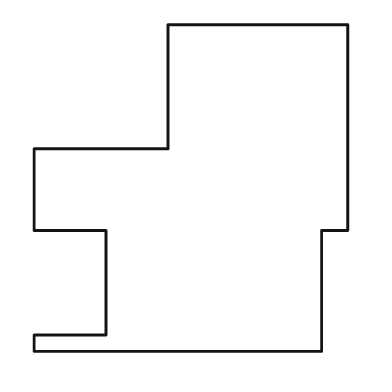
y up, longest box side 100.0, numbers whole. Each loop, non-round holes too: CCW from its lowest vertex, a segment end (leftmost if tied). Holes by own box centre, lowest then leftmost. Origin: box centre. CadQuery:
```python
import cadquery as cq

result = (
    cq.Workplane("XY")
    .moveTo(-48.0, -50.0)
    .lineTo(40.0, -50.0)
    .lineTo(40.0, -13.0)
    .lineTo(48.0, -13.0)
    .lineTo(48.0, 50.0)
    .lineTo(-7.0, 50.0)
    .lineTo(-7.0, 12.0)
    .lineTo(-48.0, 12.0)
    .lineTo(-48.0, -13.0)
    .lineTo(-26.0, -13.0)
    .lineTo(-26.0, -45.0)
    .lineTo(-48.0, -45.0)
    .close()
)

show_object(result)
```